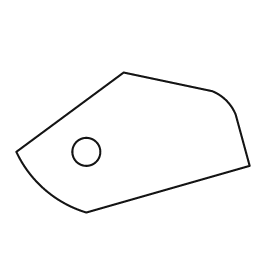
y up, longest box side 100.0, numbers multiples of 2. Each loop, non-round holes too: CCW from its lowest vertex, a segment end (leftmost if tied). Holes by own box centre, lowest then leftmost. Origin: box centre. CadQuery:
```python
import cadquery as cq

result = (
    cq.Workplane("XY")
    .moveTo(-20.0, -30.0)
    .lineTo(50.0, -10.0)
    .lineTo(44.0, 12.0)
    .threePointArc((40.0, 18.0), (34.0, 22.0))
    .lineTo(-4.0, 30.0)
    .lineTo(-50.0, -4.0)
    .threePointArc((-38.0, -20.0), (-20.0, -30.0))
    .close()
    .moveTo(-20.0, -4.0)
    .circle(6.0)
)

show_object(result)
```